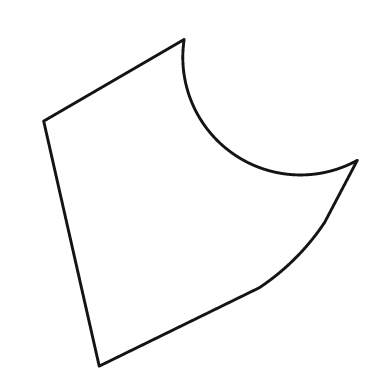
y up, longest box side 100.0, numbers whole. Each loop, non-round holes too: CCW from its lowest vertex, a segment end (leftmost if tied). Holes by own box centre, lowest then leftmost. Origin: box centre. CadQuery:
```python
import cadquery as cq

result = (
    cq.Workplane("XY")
    .moveTo(-31.0, -50.0)
    .lineTo(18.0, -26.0)
    .threePointArc((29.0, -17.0), (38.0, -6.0))
    .lineTo(48.0, 13.0)
    .threePointArc((10.0, 15.0), (-5.0, 50.0))
    .lineTo(-48.0, 25.0)
    .close()
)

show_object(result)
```